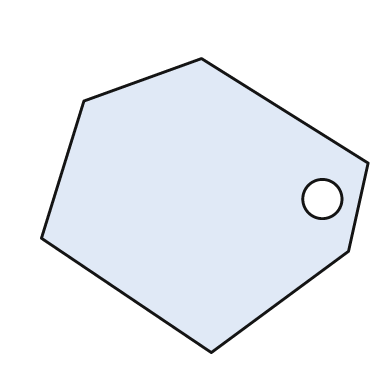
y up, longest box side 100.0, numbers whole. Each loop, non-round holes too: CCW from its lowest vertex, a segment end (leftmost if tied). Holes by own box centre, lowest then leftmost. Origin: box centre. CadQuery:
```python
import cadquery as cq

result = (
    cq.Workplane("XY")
    .moveTo(2.0, -45.0)
    .lineTo(44.0, -14.0)
    .lineTo(50.0, 13.0)
    .lineTo(-1.0, 45.0)
    .lineTo(-37.0, 32.0)
    .lineTo(-50.0, -10.0)
    .close()
    .moveTo(36.0, 2.0)
    .circle(6.0)
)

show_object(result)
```